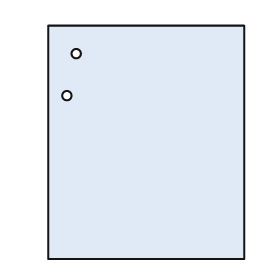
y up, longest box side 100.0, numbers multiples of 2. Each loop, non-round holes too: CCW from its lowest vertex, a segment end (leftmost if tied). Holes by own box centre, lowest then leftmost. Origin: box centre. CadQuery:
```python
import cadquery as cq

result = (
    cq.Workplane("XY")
    .moveTo(-42.0, -50.0)
    .lineTo(42.0, -50.0)
    .lineTo(42.0, 50.0)
    .lineTo(-42.0, 50.0)
    .close()
    .moveTo(-34.0, 20.0)
    .circle(2.0)
    .moveTo(-30.0, 38.0)
    .circle(2.0)
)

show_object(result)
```